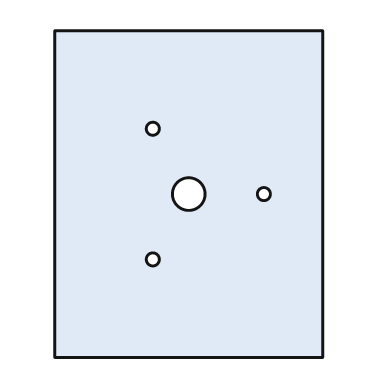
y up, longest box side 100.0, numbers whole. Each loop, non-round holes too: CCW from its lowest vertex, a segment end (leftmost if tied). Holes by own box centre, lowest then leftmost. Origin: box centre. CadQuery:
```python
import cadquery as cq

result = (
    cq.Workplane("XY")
    .moveTo(-41.0, -50.0)
    .lineTo(41.0, -50.0)
    .lineTo(41.0, 50.0)
    .lineTo(-41.0, 50.0)
    .close()
    .moveTo(-11.0, -20.0)
    .circle(2.0)
    .moveTo(0.0, 0.0)
    .circle(5.0)
    .moveTo(23.0, 0.0)
    .circle(2.0)
    .moveTo(-11.0, 20.0)
    .circle(2.0)
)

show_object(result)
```